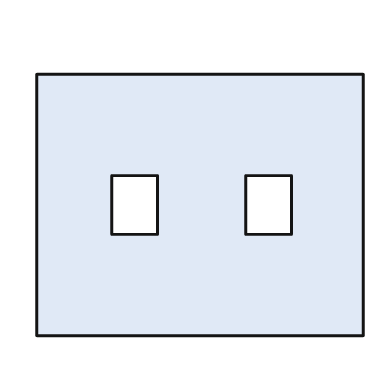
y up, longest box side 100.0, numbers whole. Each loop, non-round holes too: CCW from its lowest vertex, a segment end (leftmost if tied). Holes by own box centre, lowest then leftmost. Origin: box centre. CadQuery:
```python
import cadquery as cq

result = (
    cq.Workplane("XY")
    .moveTo(-50.0, -40.0)
    .lineTo(50.0, -40.0)
    .lineTo(50.0, 40.0)
    .lineTo(-50.0, 40.0)
    .close()
    .moveTo(-27.0, -9.0)
    .lineTo(-13.0, -9.0)
    .lineTo(-13.0, 9.0)
    .lineTo(-27.0, 9.0)
    .close()
    .moveTo(14.0, -9.0)
    .lineTo(28.0, -9.0)
    .lineTo(28.0, 9.0)
    .lineTo(14.0, 9.0)
    .close()
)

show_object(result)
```